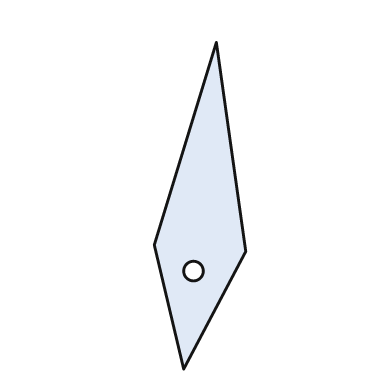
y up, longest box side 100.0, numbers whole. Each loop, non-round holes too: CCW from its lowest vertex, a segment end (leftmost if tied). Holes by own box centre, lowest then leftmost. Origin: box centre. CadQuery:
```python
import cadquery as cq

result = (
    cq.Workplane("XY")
    .moveTo(-5.0, -50.0)
    .lineTo(14.0, -14.0)
    .lineTo(5.0, 50.0)
    .lineTo(-14.0, -12.0)
    .close()
    .moveTo(-2.0, -20.0)
    .circle(3.0)
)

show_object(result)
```